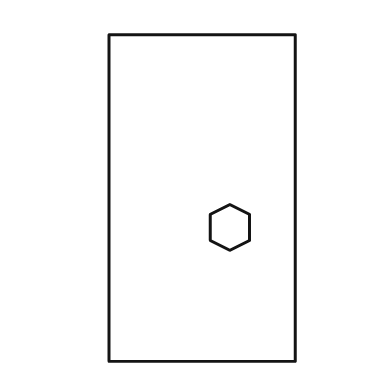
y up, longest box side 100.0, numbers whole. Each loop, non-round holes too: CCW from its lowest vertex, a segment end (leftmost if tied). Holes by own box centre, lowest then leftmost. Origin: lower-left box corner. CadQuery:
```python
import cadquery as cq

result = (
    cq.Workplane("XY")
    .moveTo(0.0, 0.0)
    .lineTo(57.0, 0.0)
    .lineTo(57.0, 100.0)
    .lineTo(0.0, 100.0)
    .close()
    .moveTo(37.0, 34.0)
    .lineTo(43.0, 37.0)
    .lineTo(43.0, 45.0)
    .lineTo(37.0, 48.0)
    .lineTo(31.0, 45.0)
    .lineTo(31.0, 37.0)
    .close()
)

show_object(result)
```